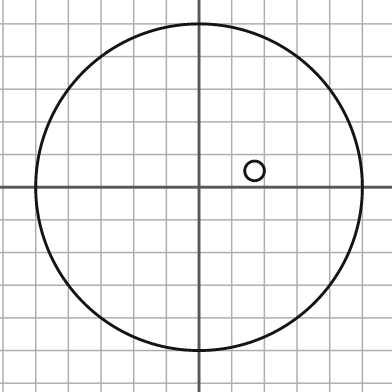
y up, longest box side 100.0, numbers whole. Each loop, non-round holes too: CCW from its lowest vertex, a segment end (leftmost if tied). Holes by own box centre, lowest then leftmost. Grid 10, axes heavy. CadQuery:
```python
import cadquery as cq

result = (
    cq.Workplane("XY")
    .moveTo(0.0, 0.0)
    .circle(50.0)
    .moveTo(17.0, 5.0)
    .circle(3.0)
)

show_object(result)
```